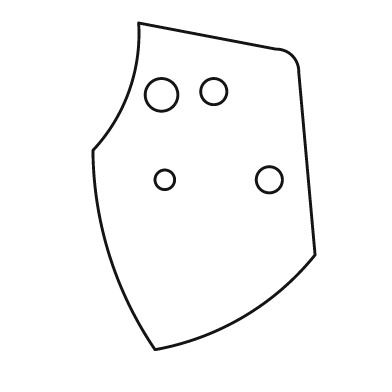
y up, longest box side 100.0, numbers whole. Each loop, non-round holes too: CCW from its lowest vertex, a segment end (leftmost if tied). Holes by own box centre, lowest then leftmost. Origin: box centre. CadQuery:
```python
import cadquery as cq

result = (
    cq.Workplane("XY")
    .moveTo(-15.0, -50.0)
    .threePointArc((12.0, -40.0), (34.0, -21.0))
    .lineTo(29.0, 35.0)
    .threePointArc((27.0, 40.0), (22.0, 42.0))
    .lineTo(-20.0, 50.0)
    .threePointArc((-23.0, 29.0), (-34.0, 11.0))
    .threePointArc((-29.0, -21.0), (-15.0, -50.0))
    .close()
    .moveTo(-12.0, 2.0)
    .circle(3.0)
    .moveTo(20.0, 2.0)
    .circle(4.0)
    .moveTo(-13.0, 28.0)
    .circle(5.0)
    .moveTo(3.0, 29.0)
    .circle(4.0)
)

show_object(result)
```